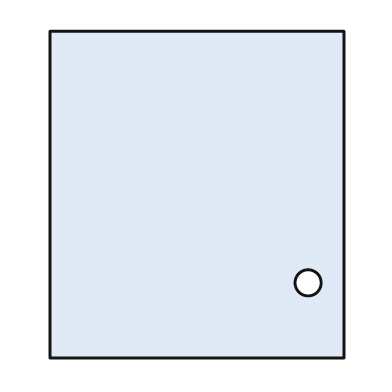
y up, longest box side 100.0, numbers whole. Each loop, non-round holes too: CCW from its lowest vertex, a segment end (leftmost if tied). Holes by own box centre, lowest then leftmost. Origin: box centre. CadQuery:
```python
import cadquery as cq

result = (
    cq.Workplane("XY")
    .moveTo(-45.0, -50.0)
    .lineTo(45.0, -50.0)
    .lineTo(45.0, 50.0)
    .lineTo(-45.0, 50.0)
    .close()
    .moveTo(34.0, -27.0)
    .circle(4.0)
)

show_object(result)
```